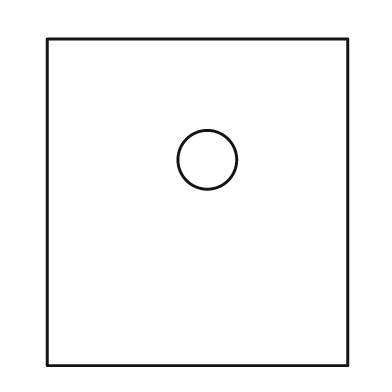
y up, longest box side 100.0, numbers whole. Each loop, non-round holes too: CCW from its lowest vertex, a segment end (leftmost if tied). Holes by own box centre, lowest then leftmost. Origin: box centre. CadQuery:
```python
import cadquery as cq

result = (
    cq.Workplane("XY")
    .moveTo(-46.0, -50.0)
    .lineTo(46.0, -50.0)
    .lineTo(46.0, 50.0)
    .lineTo(-46.0, 50.0)
    .close()
    .moveTo(3.0, 13.0)
    .circle(9.0)
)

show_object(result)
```